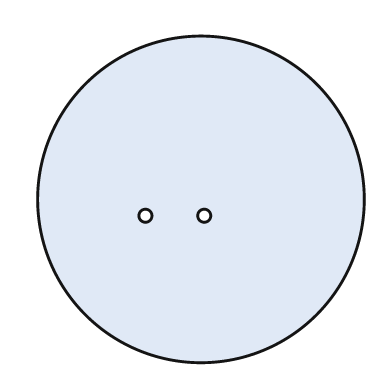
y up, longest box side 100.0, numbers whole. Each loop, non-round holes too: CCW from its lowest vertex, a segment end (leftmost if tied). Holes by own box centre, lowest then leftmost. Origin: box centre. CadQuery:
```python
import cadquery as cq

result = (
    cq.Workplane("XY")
    .moveTo(0.0, 0.0)
    .circle(50.0)
    .moveTo(-17.0, -5.0)
    .circle(2.0)
    .moveTo(1.0, -5.0)
    .circle(2.0)
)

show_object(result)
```